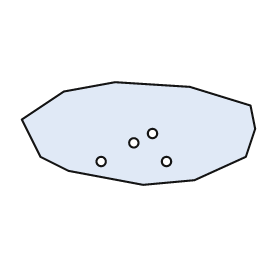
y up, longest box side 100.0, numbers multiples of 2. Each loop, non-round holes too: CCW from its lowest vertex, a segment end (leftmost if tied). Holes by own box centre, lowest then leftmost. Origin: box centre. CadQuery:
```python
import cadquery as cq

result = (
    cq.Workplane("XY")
    .moveTo(2.0, -22.0)
    .lineTo(24.0, -20.0)
    .lineTo(46.0, -10.0)
    .lineTo(50.0, 2.0)
    .lineTo(48.0, 12.0)
    .lineTo(22.0, 20.0)
    .lineTo(-10.0, 22.0)
    .lineTo(-32.0, 18.0)
    .lineTo(-50.0, 6.0)
    .lineTo(-42.0, -10.0)
    .lineTo(-30.0, -16.0)
    .close()
    .moveTo(-16.0, -12.0)
    .circle(2.0)
    .moveTo(12.0, -12.0)
    .circle(2.0)
    .moveTo(-2.0, -4.0)
    .circle(2.0)
    .moveTo(6.0, 0.0)
    .circle(2.0)
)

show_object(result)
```